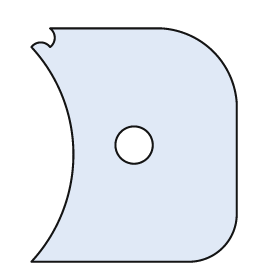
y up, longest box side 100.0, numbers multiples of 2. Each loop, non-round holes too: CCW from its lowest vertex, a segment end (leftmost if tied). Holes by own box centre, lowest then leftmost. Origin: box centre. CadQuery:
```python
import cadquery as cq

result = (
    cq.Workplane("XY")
    .moveTo(-44.0, -50.0)
    .lineTo(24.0, -50.0)
    .threePointArc((38.0, -44.0), (44.0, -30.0))
    .lineTo(44.0, 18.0)
    .threePointArc((34.0, 40.0), (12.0, 50.0))
    .lineTo(-36.0, 50.0)
    .threePointArc((-34.0, 46.0), (-36.0, 42.0))
    .threePointArc((-40.0, 44.0), (-44.0, 42.0))
    .threePointArc((-26.0, -4.0), (-44.0, -50.0))
    .close()
    .moveTo(0.0, 0.0)
    .circle(8.0)
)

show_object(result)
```